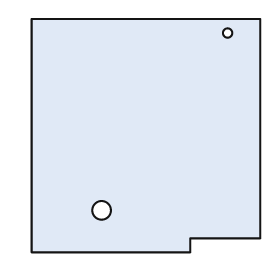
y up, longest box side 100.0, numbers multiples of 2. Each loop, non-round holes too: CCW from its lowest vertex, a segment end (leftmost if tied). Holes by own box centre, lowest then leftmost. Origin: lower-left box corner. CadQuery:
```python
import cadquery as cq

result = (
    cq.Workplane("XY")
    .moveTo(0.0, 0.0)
    .lineTo(68.0, 0.0)
    .lineTo(68.0, 6.0)
    .lineTo(98.0, 6.0)
    .lineTo(98.0, 100.0)
    .lineTo(0.0, 100.0)
    .close()
    .moveTo(30.0, 18.0)
    .circle(4.0)
    .moveTo(84.0, 94.0)
    .circle(2.0)
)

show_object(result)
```